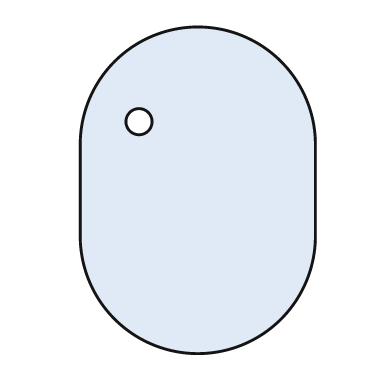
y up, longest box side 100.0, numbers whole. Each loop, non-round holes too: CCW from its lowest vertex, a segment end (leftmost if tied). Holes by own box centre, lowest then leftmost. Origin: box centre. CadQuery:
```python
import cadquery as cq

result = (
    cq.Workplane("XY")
    .moveTo(-36.0, -14.0)
    .threePointArc((0.0, -50.0), (36.0, -14.0))
    .lineTo(36.0, 14.0)
    .threePointArc((0.0, 50.0), (-36.0, 14.0))
    .close()
    .moveTo(-18.0, 21.0)
    .circle(4.0)
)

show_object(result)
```